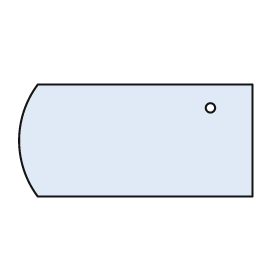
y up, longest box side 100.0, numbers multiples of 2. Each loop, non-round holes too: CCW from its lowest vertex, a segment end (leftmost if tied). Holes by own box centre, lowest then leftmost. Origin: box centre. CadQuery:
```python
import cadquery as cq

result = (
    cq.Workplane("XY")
    .moveTo(-42.0, -24.0)
    .lineTo(50.0, -24.0)
    .lineTo(50.0, 24.0)
    .lineTo(-42.0, 24.0)
    .threePointArc((-50.0, 0.0), (-42.0, -24.0))
    .close()
    .moveTo(32.0, 14.0)
    .circle(2.0)
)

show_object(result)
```